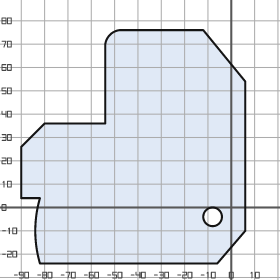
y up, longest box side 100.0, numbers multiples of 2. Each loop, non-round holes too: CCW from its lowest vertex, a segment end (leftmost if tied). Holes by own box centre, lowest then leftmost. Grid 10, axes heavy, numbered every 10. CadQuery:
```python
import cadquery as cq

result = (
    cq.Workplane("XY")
    .moveTo(-82.0, -24.0)
    .lineTo(-6.0, -24.0)
    .lineTo(6.0, -10.0)
    .lineTo(6.0, 54.0)
    .lineTo(-12.0, 76.0)
    .lineTo(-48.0, 76.0)
    .threePointArc((-52.0, 74.0), (-54.0, 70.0))
    .lineTo(-54.0, 36.0)
    .lineTo(-80.0, 36.0)
    .lineTo(-90.0, 26.0)
    .lineTo(-90.0, 4.0)
    .lineTo(-82.0, 4.0)
    .threePointArc((-84.0, -10.0), (-82.0, -24.0))
    .close()
    .moveTo(-8.0, -4.0)
    .circle(4.0)
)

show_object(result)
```